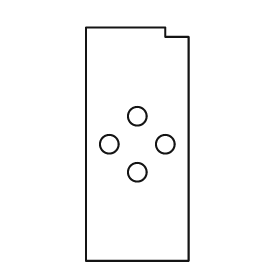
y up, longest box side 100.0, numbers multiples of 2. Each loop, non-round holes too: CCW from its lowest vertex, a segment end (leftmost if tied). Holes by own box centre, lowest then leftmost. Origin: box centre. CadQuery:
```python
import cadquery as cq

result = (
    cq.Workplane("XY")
    .moveTo(-22.0, -50.0)
    .lineTo(22.0, -50.0)
    .lineTo(22.0, 46.0)
    .lineTo(12.0, 46.0)
    .lineTo(12.0, 50.0)
    .lineTo(-22.0, 50.0)
    .close()
    .moveTo(0.0, -12.0)
    .circle(4.0)
    .moveTo(-12.0, 0.0)
    .circle(4.0)
    .moveTo(12.0, 0.0)
    .circle(4.0)
    .moveTo(0.0, 12.0)
    .circle(4.0)
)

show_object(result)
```